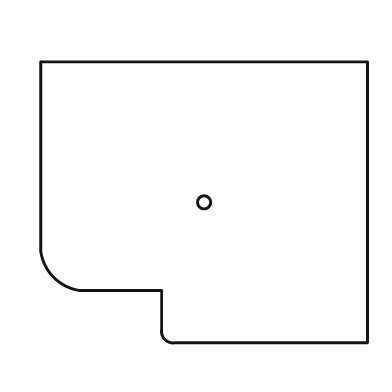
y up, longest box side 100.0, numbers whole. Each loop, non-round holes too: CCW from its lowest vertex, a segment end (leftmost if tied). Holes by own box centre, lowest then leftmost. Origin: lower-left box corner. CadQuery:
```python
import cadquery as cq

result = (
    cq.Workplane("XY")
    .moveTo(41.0, 0.0)
    .lineTo(100.0, 0.0)
    .lineTo(100.0, 86.0)
    .lineTo(0.0, 86.0)
    .lineTo(0.0, 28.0)
    .threePointArc((4.0, 20.0), (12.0, 16.0))
    .lineTo(37.0, 16.0)
    .lineTo(37.0, 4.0)
    .threePointArc((38.0, 1.0), (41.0, 0.0))
    .close()
    .moveTo(50.0, 43.0)
    .circle(2.0)
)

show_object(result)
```